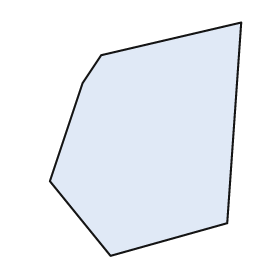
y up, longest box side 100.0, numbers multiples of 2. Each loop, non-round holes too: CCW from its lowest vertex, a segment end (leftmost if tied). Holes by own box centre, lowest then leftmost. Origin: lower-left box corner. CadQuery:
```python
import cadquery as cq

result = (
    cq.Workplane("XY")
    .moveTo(26.0, 0.0)
    .lineTo(76.0, 14.0)
    .lineTo(82.0, 100.0)
    .lineTo(22.0, 86.0)
    .lineTo(14.0, 74.0)
    .lineTo(0.0, 32.0)
    .close()
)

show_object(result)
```